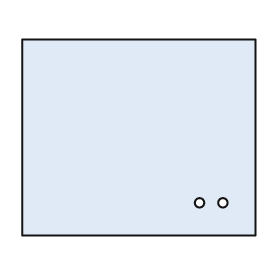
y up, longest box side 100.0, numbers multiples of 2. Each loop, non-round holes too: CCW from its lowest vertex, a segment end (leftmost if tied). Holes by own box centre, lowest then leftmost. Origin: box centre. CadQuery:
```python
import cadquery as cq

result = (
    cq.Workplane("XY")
    .moveTo(-50.0, -42.0)
    .lineTo(50.0, -42.0)
    .lineTo(50.0, 42.0)
    .lineTo(-50.0, 42.0)
    .close()
    .moveTo(26.0, -28.0)
    .circle(2.0)
    .moveTo(36.0, -28.0)
    .circle(2.0)
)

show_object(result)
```